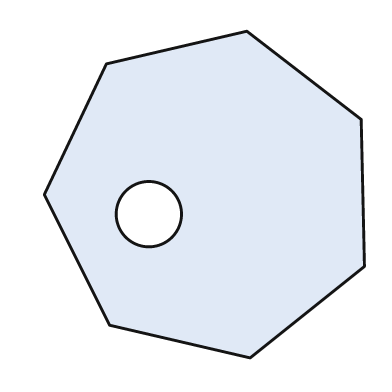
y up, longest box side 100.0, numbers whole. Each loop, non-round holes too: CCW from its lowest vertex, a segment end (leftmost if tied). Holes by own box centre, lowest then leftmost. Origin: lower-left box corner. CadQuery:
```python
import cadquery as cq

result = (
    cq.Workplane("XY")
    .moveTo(63.0, 0.0)
    .lineTo(98.0, 28.0)
    .lineTo(97.0, 73.0)
    .lineTo(62.0, 100.0)
    .lineTo(19.0, 90.0)
    .lineTo(0.0, 50.0)
    .lineTo(20.0, 10.0)
    .close()
    .moveTo(32.0, 44.0)
    .circle(10.0)
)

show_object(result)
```